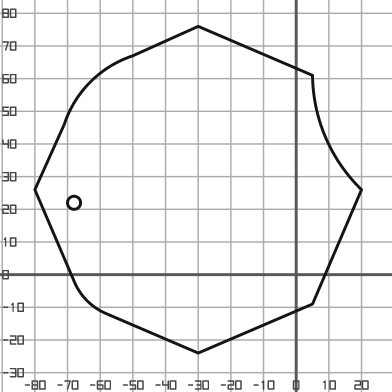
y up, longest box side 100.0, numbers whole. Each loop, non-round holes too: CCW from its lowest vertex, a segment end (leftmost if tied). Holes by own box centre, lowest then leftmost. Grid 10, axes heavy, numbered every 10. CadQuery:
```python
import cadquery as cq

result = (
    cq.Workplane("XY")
    .moveTo(-30.0, -24.0)
    .lineTo(5.0, -9.0)
    .lineTo(20.0, 26.0)
    .threePointArc((9.0, 42.0), (5.0, 61.0))
    .lineTo(-30.0, 76.0)
    .lineTo(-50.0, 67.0)
    .threePointArc((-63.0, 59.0), (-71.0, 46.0))
    .lineTo(-80.0, 26.0)
    .lineTo(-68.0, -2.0)
    .threePointArc((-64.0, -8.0), (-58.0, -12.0))
    .close()
    .moveTo(-68.0, 22.0)
    .circle(2.0)
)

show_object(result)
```